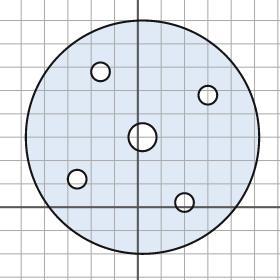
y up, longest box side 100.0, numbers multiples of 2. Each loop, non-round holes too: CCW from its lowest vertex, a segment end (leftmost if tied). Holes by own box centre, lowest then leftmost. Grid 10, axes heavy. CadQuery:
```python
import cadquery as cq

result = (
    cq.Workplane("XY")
    .moveTo(2.0, 30.0)
    .circle(50.0)
    .moveTo(20.0, 2.0)
    .circle(4.0)
    .moveTo(-26.0, 12.0)
    .circle(4.0)
    .moveTo(2.0, 30.0)
    .circle(6.0)
    .moveTo(30.0, 48.0)
    .circle(4.0)
    .moveTo(-16.0, 58.0)
    .circle(4.0)
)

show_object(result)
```